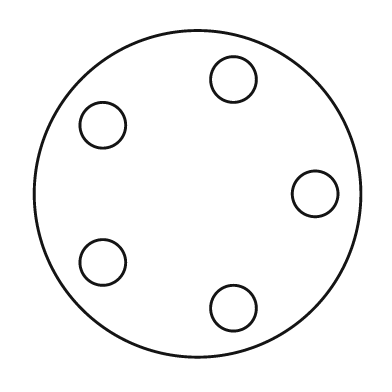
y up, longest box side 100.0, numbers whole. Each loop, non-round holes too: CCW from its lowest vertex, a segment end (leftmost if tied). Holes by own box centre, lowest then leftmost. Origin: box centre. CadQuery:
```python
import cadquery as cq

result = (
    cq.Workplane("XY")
    .moveTo(0.0, 0.0)
    .circle(50.0)
    .moveTo(11.0, -35.0)
    .circle(7.0)
    .moveTo(-29.0, -21.0)
    .circle(7.0)
    .moveTo(36.0, 0.0)
    .circle(7.0)
    .moveTo(-29.0, 21.0)
    .circle(7.0)
    .moveTo(11.0, 35.0)
    .circle(7.0)
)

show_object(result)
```